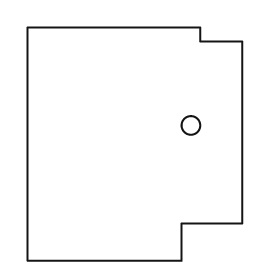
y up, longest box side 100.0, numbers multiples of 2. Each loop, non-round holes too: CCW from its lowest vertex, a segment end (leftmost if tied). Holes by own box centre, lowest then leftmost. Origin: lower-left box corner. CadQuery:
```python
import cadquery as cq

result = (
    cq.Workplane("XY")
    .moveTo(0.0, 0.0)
    .lineTo(66.0, 0.0)
    .lineTo(66.0, 16.0)
    .lineTo(92.0, 16.0)
    .lineTo(92.0, 94.0)
    .lineTo(74.0, 94.0)
    .lineTo(74.0, 100.0)
    .lineTo(0.0, 100.0)
    .close()
    .moveTo(70.0, 58.0)
    .circle(4.0)
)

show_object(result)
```